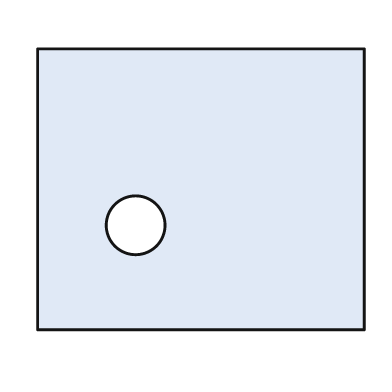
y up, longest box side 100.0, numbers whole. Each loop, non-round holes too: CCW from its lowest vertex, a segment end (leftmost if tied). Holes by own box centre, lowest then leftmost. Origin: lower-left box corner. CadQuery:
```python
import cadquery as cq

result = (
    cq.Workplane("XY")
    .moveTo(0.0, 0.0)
    .lineTo(100.0, 0.0)
    .lineTo(100.0, 86.0)
    .lineTo(0.0, 86.0)
    .close()
    .moveTo(30.0, 32.0)
    .circle(9.0)
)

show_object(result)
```